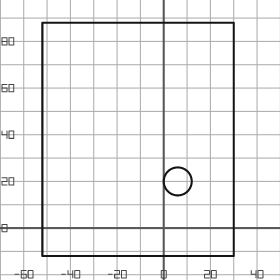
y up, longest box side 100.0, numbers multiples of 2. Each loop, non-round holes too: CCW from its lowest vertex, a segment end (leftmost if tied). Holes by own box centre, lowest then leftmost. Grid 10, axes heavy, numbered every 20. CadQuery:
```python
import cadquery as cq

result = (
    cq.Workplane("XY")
    .moveTo(-52.0, -12.0)
    .lineTo(30.0, -12.0)
    .lineTo(30.0, 88.0)
    .lineTo(-52.0, 88.0)
    .close()
    .moveTo(6.0, 20.0)
    .circle(6.0)
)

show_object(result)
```